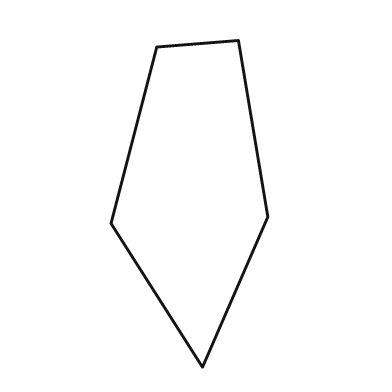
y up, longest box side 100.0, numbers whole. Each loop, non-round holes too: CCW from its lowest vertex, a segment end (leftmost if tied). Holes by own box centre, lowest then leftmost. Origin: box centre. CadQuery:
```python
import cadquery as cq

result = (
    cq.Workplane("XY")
    .moveTo(4.0, -50.0)
    .lineTo(24.0, -4.0)
    .lineTo(15.0, 50.0)
    .lineTo(-10.0, 48.0)
    .lineTo(-24.0, -6.0)
    .close()
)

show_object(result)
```